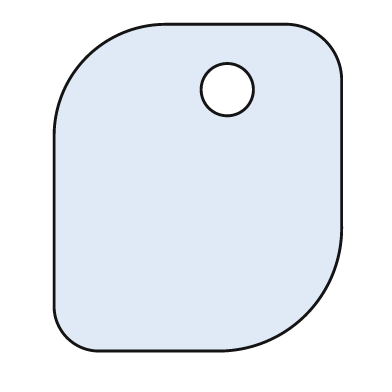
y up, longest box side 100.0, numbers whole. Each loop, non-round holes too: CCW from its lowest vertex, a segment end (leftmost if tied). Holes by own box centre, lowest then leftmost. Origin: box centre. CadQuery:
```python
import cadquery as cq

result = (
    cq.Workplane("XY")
    .moveTo(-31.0, -50.0)
    .lineTo(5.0, -50.0)
    .threePointArc((33.0, -39.0), (44.0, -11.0))
    .lineTo(44.0, 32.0)
    .threePointArc((39.0, 45.0), (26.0, 50.0))
    .lineTo(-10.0, 50.0)
    .threePointArc((-34.0, 40.0), (-44.0, 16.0))
    .lineTo(-44.0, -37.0)
    .threePointArc((-40.0, -46.0), (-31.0, -50.0))
    .close()
    .moveTo(9.0, 30.0)
    .circle(8.0)
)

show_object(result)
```